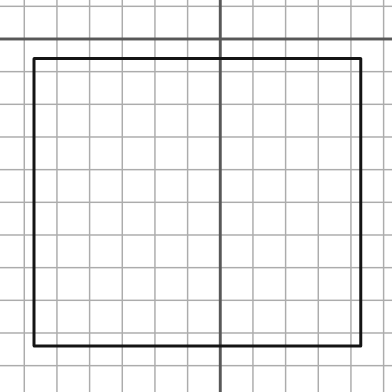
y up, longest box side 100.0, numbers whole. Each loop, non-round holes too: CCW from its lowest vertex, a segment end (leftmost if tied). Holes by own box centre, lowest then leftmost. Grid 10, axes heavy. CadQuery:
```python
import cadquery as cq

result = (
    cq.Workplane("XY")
    .moveTo(-57.0, -94.0)
    .lineTo(43.0, -94.0)
    .lineTo(43.0, -6.0)
    .lineTo(-57.0, -6.0)
    .close()
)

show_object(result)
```